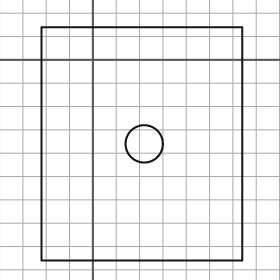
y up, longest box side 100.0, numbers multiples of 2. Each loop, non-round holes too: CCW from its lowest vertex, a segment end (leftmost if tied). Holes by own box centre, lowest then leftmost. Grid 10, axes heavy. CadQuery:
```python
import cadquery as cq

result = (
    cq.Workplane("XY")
    .moveTo(-22.0, -86.0)
    .lineTo(64.0, -86.0)
    .lineTo(64.0, 14.0)
    .lineTo(-22.0, 14.0)
    .close()
    .moveTo(22.0, -36.0)
    .circle(8.0)
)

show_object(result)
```